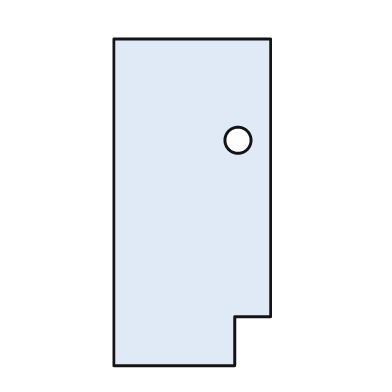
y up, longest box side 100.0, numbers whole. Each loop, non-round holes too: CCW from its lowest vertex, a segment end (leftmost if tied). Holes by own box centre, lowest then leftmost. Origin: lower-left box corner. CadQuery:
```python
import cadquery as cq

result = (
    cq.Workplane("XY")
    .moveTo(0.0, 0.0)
    .lineTo(37.0, 0.0)
    .lineTo(37.0, 15.0)
    .lineTo(48.0, 15.0)
    .lineTo(48.0, 100.0)
    .lineTo(0.0, 100.0)
    .close()
    .moveTo(38.0, 69.0)
    .circle(4.0)
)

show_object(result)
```